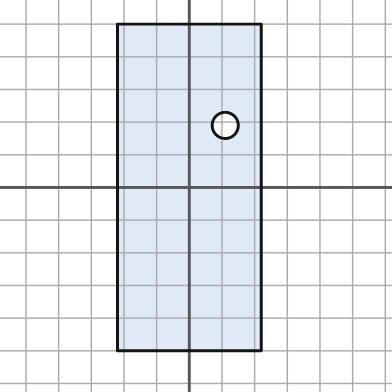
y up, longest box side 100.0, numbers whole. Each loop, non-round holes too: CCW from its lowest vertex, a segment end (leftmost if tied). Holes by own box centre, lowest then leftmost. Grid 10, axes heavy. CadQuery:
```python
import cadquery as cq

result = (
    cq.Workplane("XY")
    .moveTo(-22.0, -50.0)
    .lineTo(22.0, -50.0)
    .lineTo(22.0, 50.0)
    .lineTo(-22.0, 50.0)
    .close()
    .moveTo(11.0, 19.0)
    .circle(4.0)
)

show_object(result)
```